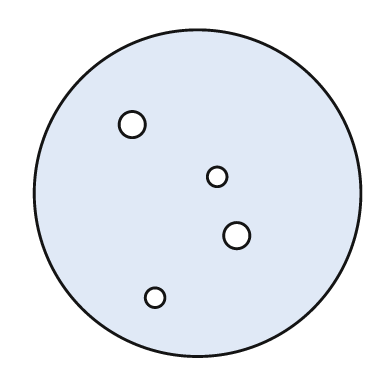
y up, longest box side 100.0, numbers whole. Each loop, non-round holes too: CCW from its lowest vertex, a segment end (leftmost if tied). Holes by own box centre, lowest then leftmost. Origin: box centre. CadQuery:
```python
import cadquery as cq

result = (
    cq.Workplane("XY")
    .moveTo(0.0, 0.0)
    .circle(50.0)
    .moveTo(-13.0, -32.0)
    .circle(3.0)
    .moveTo(12.0, -13.0)
    .circle(4.0)
    .moveTo(6.0, 5.0)
    .circle(3.0)
    .moveTo(-20.0, 21.0)
    .circle(4.0)
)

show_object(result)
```